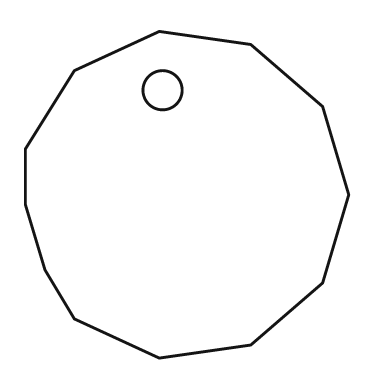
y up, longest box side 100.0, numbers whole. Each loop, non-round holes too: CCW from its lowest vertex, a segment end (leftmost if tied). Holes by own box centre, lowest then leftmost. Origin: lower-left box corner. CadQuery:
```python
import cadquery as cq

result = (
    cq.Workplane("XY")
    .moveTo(41.0, 0.0)
    .lineTo(69.0, 4.0)
    .lineTo(91.0, 23.0)
    .lineTo(99.0, 50.0)
    .lineTo(91.0, 77.0)
    .lineTo(69.0, 96.0)
    .lineTo(41.0, 100.0)
    .lineTo(15.0, 88.0)
    .lineTo(0.0, 64.0)
    .lineTo(0.0, 47.0)
    .lineTo(6.0, 27.0)
    .lineTo(15.0, 12.0)
    .close()
    .moveTo(42.0, 82.0)
    .circle(6.0)
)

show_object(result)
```